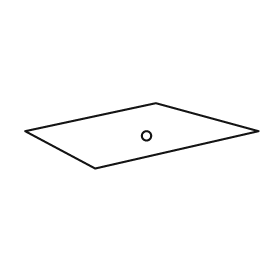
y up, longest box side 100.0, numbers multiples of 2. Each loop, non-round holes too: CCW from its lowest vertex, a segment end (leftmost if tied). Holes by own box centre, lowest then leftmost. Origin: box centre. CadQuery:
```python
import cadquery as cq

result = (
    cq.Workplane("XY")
    .moveTo(-20.0, -14.0)
    .lineTo(50.0, 2.0)
    .lineTo(6.0, 14.0)
    .lineTo(-50.0, 2.0)
    .close()
    .moveTo(2.0, 0.0)
    .circle(2.0)
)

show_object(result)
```